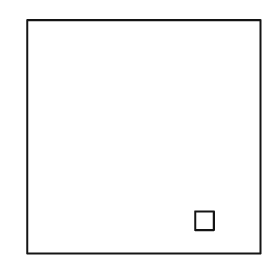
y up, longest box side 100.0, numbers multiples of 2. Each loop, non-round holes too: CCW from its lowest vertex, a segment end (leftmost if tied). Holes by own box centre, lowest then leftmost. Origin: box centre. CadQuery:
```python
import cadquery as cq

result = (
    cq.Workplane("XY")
    .moveTo(-50.0, -50.0)
    .lineTo(50.0, -50.0)
    .lineTo(50.0, 50.0)
    .lineTo(-50.0, 50.0)
    .close()
    .moveTo(22.0, -40.0)
    .lineTo(30.0, -40.0)
    .lineTo(30.0, -32.0)
    .lineTo(22.0, -32.0)
    .close()
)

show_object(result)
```